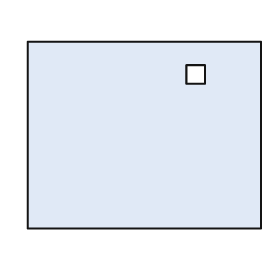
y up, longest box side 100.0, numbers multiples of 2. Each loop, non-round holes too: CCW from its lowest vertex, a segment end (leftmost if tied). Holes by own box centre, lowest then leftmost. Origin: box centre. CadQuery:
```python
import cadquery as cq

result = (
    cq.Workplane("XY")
    .moveTo(-50.0, -40.0)
    .lineTo(50.0, -40.0)
    .lineTo(50.0, 40.0)
    .lineTo(-50.0, 40.0)
    .close()
    .moveTo(18.0, 22.0)
    .lineTo(26.0, 22.0)
    .lineTo(26.0, 30.0)
    .lineTo(18.0, 30.0)
    .close()
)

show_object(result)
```